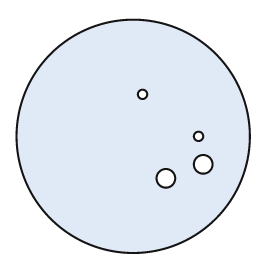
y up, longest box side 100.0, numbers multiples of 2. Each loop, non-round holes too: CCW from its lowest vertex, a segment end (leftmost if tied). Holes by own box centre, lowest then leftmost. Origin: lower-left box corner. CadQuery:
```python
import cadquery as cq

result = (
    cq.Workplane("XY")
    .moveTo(50.0, 50.0)
    .circle(50.0)
    .moveTo(64.0, 32.0)
    .circle(4.0)
    .moveTo(80.0, 38.0)
    .circle(4.0)
    .moveTo(78.0, 50.0)
    .circle(2.0)
    .moveTo(54.0, 68.0)
    .circle(2.0)
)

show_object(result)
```